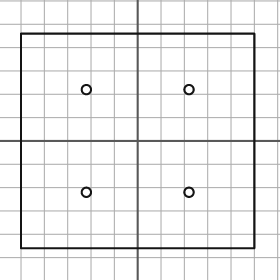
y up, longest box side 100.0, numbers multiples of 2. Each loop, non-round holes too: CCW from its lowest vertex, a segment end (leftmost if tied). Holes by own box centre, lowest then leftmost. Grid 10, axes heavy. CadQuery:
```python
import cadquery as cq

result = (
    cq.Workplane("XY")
    .moveTo(-50.0, -46.0)
    .lineTo(50.0, -46.0)
    .lineTo(50.0, 46.0)
    .lineTo(-50.0, 46.0)
    .close()
    .moveTo(-22.0, -22.0)
    .circle(2.0)
    .moveTo(22.0, -22.0)
    .circle(2.0)
    .moveTo(-22.0, 22.0)
    .circle(2.0)
    .moveTo(22.0, 22.0)
    .circle(2.0)
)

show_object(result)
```